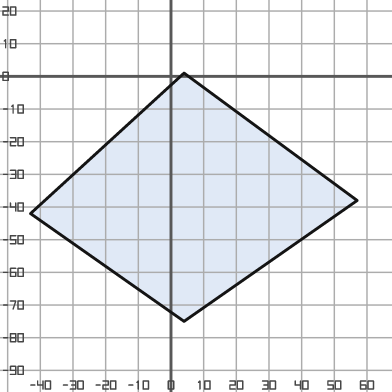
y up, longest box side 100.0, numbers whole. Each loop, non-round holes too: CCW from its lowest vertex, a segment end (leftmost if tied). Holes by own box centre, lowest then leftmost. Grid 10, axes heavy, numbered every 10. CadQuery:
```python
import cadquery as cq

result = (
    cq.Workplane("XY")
    .moveTo(4.0, -75.0)
    .lineTo(57.0, -38.0)
    .lineTo(4.0, 1.0)
    .lineTo(-43.0, -42.0)
    .close()
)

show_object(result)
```